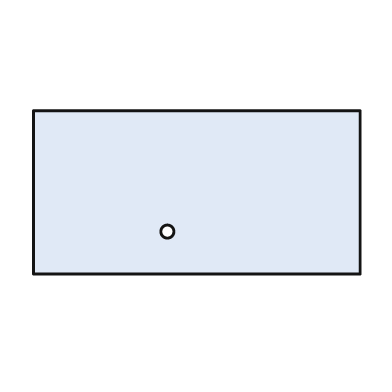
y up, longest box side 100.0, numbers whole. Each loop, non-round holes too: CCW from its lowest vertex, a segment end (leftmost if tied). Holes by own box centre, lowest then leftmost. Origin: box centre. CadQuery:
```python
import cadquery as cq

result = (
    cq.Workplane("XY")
    .moveTo(-50.0, -25.0)
    .lineTo(50.0, -25.0)
    .lineTo(50.0, 25.0)
    .lineTo(-50.0, 25.0)
    .close()
    .moveTo(-9.0, -12.0)
    .circle(2.0)
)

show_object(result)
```